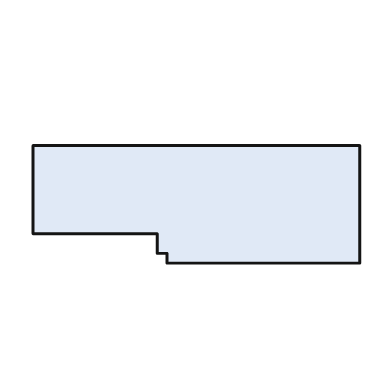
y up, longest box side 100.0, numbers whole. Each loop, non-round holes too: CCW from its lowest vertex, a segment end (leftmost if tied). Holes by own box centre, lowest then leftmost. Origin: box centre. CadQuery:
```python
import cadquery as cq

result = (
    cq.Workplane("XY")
    .moveTo(-9.0, -18.0)
    .lineTo(50.0, -18.0)
    .lineTo(50.0, 18.0)
    .lineTo(-50.0, 18.0)
    .lineTo(-50.0, -9.0)
    .lineTo(-12.0, -9.0)
    .lineTo(-12.0, -15.0)
    .lineTo(-9.0, -15.0)
    .close()
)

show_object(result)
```